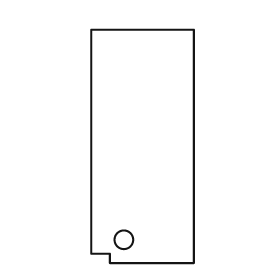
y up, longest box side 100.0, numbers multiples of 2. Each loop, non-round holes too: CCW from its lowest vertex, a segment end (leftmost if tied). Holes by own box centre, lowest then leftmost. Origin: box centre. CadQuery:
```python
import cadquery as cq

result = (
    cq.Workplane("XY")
    .moveTo(-14.0, -50.0)
    .lineTo(22.0, -50.0)
    .lineTo(22.0, 50.0)
    .lineTo(-22.0, 50.0)
    .lineTo(-22.0, -46.0)
    .lineTo(-14.0, -46.0)
    .close()
    .moveTo(-8.0, -40.0)
    .circle(4.0)
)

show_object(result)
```